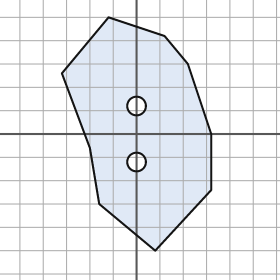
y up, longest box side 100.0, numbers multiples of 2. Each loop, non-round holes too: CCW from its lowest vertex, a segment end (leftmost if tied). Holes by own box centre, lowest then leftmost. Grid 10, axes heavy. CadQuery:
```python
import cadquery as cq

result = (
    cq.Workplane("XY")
    .moveTo(8.0, -50.0)
    .lineTo(32.0, -24.0)
    .lineTo(32.0, 0.0)
    .lineTo(22.0, 30.0)
    .lineTo(12.0, 42.0)
    .lineTo(-12.0, 50.0)
    .lineTo(-32.0, 26.0)
    .lineTo(-20.0, -6.0)
    .lineTo(-16.0, -30.0)
    .close()
    .moveTo(0.0, -12.0)
    .circle(4.0)
    .moveTo(0.0, 12.0)
    .circle(4.0)
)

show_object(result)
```